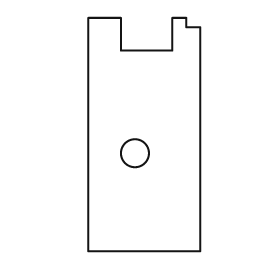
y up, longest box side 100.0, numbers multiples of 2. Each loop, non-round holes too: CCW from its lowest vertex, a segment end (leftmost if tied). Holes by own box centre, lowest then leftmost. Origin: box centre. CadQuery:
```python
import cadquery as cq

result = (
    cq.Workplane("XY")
    .moveTo(-24.0, -50.0)
    .lineTo(24.0, -50.0)
    .lineTo(24.0, 46.0)
    .lineTo(18.0, 46.0)
    .lineTo(18.0, 50.0)
    .lineTo(12.0, 50.0)
    .lineTo(12.0, 36.0)
    .lineTo(-10.0, 36.0)
    .lineTo(-10.0, 50.0)
    .lineTo(-24.0, 50.0)
    .close()
    .moveTo(-4.0, -8.0)
    .circle(6.0)
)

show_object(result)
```